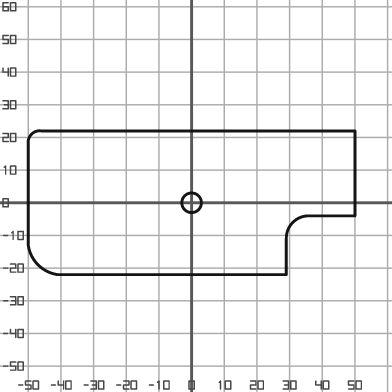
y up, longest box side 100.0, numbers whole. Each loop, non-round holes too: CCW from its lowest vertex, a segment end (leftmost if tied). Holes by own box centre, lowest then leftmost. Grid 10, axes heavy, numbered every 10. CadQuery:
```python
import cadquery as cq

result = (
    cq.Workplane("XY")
    .moveTo(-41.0, -22.0)
    .lineTo(29.0, -22.0)
    .lineTo(29.0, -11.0)
    .threePointArc((31.0, -6.0), (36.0, -4.0))
    .lineTo(50.0, -4.0)
    .lineTo(50.0, 22.0)
    .lineTo(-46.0, 22.0)
    .threePointArc((-49.0, 21.0), (-50.0, 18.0))
    .lineTo(-50.0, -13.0)
    .threePointArc((-47.0, -19.0), (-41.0, -22.0))
    .close()
    .moveTo(0.0, 0.0)
    .circle(3.0)
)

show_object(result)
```